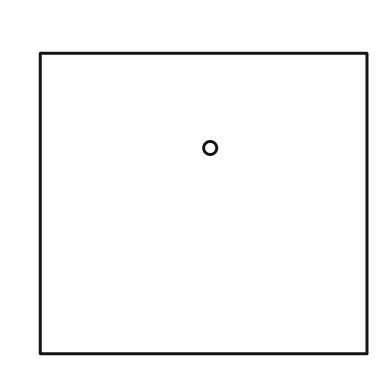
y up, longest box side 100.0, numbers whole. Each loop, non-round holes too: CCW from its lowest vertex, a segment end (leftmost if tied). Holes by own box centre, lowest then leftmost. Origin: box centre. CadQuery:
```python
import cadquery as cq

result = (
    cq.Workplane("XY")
    .moveTo(-50.0, -46.0)
    .lineTo(50.0, -46.0)
    .lineTo(50.0, 46.0)
    .lineTo(-50.0, 46.0)
    .close()
    .moveTo(2.0, 17.0)
    .circle(2.0)
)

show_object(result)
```